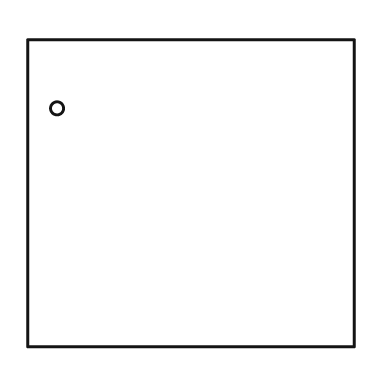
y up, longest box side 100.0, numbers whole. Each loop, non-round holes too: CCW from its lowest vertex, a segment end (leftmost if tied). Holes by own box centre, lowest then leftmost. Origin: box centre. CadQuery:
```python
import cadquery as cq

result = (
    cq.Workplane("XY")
    .moveTo(-50.0, -47.0)
    .lineTo(50.0, -47.0)
    .lineTo(50.0, 47.0)
    .lineTo(-50.0, 47.0)
    .close()
    .moveTo(-41.0, 26.0)
    .circle(2.0)
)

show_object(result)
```